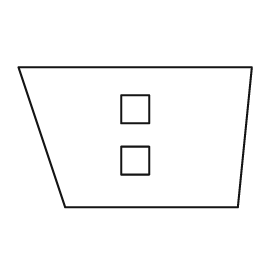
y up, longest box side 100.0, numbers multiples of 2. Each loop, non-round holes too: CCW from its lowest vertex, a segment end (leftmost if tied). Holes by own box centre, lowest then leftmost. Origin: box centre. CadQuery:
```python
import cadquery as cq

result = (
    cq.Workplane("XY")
    .moveTo(-30.0, -30.0)
    .lineTo(44.0, -30.0)
    .lineTo(50.0, 30.0)
    .lineTo(-50.0, 30.0)
    .close()
    .moveTo(-6.0, -16.0)
    .lineTo(6.0, -16.0)
    .lineTo(6.0, -4.0)
    .lineTo(-6.0, -4.0)
    .close()
    .moveTo(-6.0, 6.0)
    .lineTo(6.0, 6.0)
    .lineTo(6.0, 18.0)
    .lineTo(-6.0, 18.0)
    .close()
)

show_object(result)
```